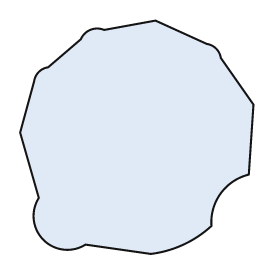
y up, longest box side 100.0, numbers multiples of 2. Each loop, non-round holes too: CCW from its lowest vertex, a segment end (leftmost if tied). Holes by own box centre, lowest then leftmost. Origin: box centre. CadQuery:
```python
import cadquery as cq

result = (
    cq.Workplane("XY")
    .moveTo(6.0, -50.0)
    .threePointArc((20.0, -46.0), (32.0, -38.0))
    .threePointArc((36.0, -24.0), (48.0, -16.0))
    .lineTo(50.0, 14.0)
    .lineTo(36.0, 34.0)
    .threePointArc((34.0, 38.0), (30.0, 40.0))
    .lineTo(8.0, 50.0)
    .lineTo(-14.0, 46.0)
    .threePointArc((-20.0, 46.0), (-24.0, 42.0))
    .lineTo(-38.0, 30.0)
    .threePointArc((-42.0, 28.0), (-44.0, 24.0))
    .lineTo(-50.0, 2.0)
    .lineTo(-42.0, -26.0)
    .threePointArc((-40.0, -44.0), (-22.0, -46.0))
    .close()
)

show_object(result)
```